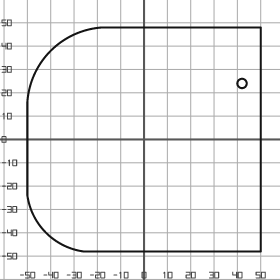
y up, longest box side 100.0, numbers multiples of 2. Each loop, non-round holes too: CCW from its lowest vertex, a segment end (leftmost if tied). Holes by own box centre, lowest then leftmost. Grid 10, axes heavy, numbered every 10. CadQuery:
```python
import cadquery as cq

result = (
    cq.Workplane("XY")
    .moveTo(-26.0, -48.0)
    .lineTo(50.0, -48.0)
    .lineTo(50.0, 48.0)
    .lineTo(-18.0, 48.0)
    .threePointArc((-40.0, 38.0), (-50.0, 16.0))
    .lineTo(-50.0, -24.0)
    .threePointArc((-42.0, -40.0), (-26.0, -48.0))
    .close()
    .moveTo(42.0, 24.0)
    .circle(2.0)
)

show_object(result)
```